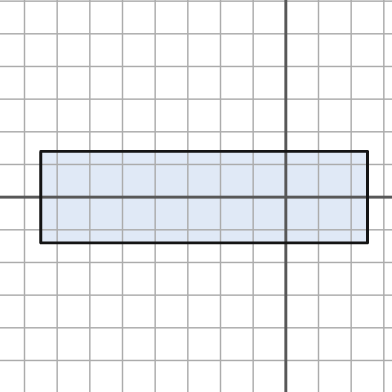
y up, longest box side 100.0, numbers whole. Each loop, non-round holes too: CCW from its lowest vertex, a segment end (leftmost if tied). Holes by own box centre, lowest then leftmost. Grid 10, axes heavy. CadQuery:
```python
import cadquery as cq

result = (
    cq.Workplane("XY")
    .moveTo(-75.0, -14.0)
    .lineTo(25.0, -14.0)
    .lineTo(25.0, 14.0)
    .lineTo(-75.0, 14.0)
    .close()
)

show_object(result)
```